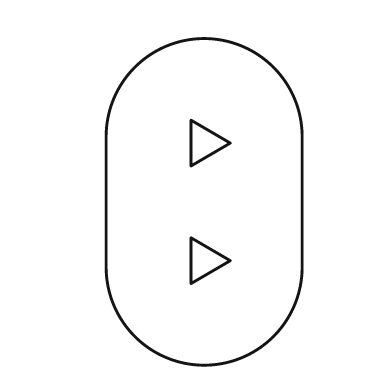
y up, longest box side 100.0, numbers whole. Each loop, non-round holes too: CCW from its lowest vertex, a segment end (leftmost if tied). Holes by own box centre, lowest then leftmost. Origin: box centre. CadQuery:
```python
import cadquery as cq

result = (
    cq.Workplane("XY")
    .moveTo(-30.0, -20.0)
    .threePointArc((0.0, -50.0), (30.0, -20.0))
    .lineTo(30.0, 20.0)
    .threePointArc((0.0, 50.0), (-30.0, 20.0))
    .close()
    .moveTo(-4.0, -25.0)
    .lineTo(8.0, -18.0)
    .lineTo(-4.0, -11.0)
    .close()
    .moveTo(-4.0, 11.0)
    .lineTo(8.0, 18.0)
    .lineTo(-4.0, 25.0)
    .close()
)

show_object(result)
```